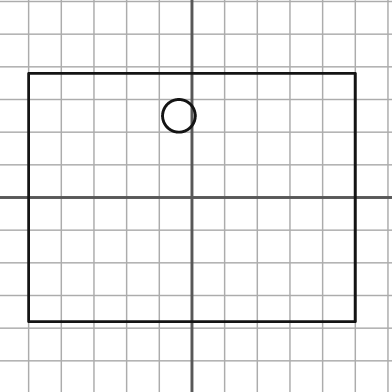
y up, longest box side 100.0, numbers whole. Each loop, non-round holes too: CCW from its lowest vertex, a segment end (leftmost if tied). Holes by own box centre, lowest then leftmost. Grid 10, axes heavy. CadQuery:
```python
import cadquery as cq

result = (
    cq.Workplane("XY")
    .moveTo(-50.0, -38.0)
    .lineTo(50.0, -38.0)
    .lineTo(50.0, 38.0)
    .lineTo(-50.0, 38.0)
    .close()
    .moveTo(-4.0, 25.0)
    .circle(5.0)
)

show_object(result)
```